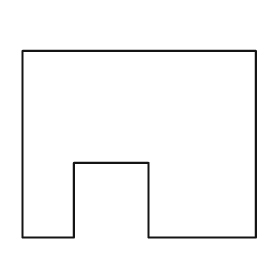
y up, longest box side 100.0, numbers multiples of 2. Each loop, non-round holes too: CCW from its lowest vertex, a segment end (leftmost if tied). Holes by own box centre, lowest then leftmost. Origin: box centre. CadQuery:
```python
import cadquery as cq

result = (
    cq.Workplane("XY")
    .moveTo(-50.0, -40.0)
    .lineTo(-28.0, -40.0)
    .lineTo(-28.0, -8.0)
    .lineTo(4.0, -8.0)
    .lineTo(4.0, -40.0)
    .lineTo(50.0, -40.0)
    .lineTo(50.0, 40.0)
    .lineTo(-50.0, 40.0)
    .close()
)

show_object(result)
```